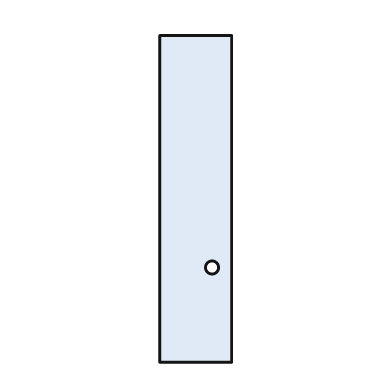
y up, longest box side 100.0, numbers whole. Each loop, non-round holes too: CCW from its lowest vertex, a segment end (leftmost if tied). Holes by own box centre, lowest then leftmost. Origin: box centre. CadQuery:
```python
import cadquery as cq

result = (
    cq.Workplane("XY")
    .moveTo(-11.0, -50.0)
    .lineTo(11.0, -50.0)
    .lineTo(11.0, 50.0)
    .lineTo(-11.0, 50.0)
    .close()
    .moveTo(5.0, -21.0)
    .circle(2.0)
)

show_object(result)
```